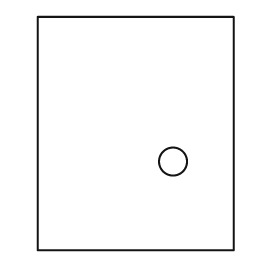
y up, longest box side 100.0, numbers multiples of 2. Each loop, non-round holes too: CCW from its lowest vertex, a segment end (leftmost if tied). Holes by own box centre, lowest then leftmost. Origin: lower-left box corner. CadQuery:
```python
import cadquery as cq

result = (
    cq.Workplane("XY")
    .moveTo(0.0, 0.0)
    .lineTo(84.0, 0.0)
    .lineTo(84.0, 100.0)
    .lineTo(0.0, 100.0)
    .close()
    .moveTo(58.0, 38.0)
    .circle(6.0)
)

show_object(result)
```